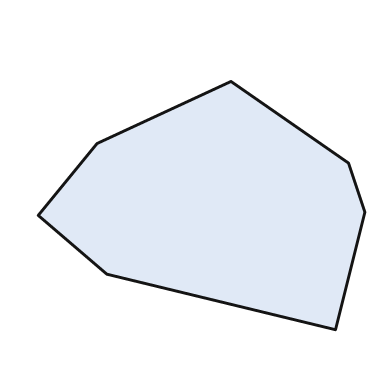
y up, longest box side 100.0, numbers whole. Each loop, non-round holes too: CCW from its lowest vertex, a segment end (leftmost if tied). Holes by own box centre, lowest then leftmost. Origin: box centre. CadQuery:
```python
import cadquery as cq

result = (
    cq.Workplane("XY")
    .moveTo(41.0, -38.0)
    .lineTo(50.0, -2.0)
    .lineTo(45.0, 13.0)
    .lineTo(9.0, 38.0)
    .lineTo(-32.0, 19.0)
    .lineTo(-50.0, -3.0)
    .lineTo(-29.0, -21.0)
    .close()
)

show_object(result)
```